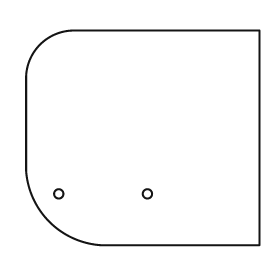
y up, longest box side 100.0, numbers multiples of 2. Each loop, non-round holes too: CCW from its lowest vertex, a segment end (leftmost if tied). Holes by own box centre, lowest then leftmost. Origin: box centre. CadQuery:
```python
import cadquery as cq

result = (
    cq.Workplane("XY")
    .moveTo(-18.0, -46.0)
    .lineTo(50.0, -46.0)
    .lineTo(50.0, 46.0)
    .lineTo(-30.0, 46.0)
    .threePointArc((-44.0, 40.0), (-50.0, 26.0))
    .lineTo(-50.0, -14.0)
    .threePointArc((-40.0, -36.0), (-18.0, -46.0))
    .close()
    .moveTo(-36.0, -24.0)
    .circle(2.0)
    .moveTo(2.0, -24.0)
    .circle(2.0)
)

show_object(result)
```